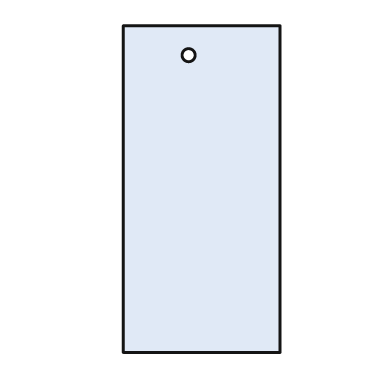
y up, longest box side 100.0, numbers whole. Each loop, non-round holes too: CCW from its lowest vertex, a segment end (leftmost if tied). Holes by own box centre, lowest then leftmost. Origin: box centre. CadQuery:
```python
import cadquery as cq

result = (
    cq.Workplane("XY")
    .moveTo(-24.0, -50.0)
    .lineTo(24.0, -50.0)
    .lineTo(24.0, 50.0)
    .lineTo(-24.0, 50.0)
    .close()
    .moveTo(-4.0, 41.0)
    .circle(2.0)
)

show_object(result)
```